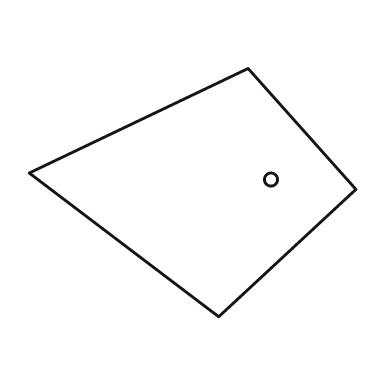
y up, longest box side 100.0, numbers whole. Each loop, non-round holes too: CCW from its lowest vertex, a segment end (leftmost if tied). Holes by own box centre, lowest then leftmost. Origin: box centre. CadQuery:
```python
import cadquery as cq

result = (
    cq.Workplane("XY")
    .moveTo(8.0, -38.0)
    .lineTo(50.0, 1.0)
    .lineTo(17.0, 38.0)
    .lineTo(-50.0, 6.0)
    .close()
    .moveTo(24.0, 4.0)
    .circle(2.0)
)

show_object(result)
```